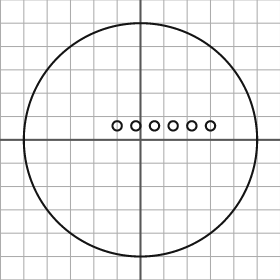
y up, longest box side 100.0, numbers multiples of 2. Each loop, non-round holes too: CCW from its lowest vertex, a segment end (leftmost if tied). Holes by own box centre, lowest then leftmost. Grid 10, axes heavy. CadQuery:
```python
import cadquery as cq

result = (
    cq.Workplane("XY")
    .moveTo(0.0, 0.0)
    .circle(50.0)
    .moveTo(-10.0, 6.0)
    .circle(2.0)
    .moveTo(-2.0, 6.0)
    .circle(2.0)
    .moveTo(6.0, 6.0)
    .circle(2.0)
    .moveTo(14.0, 6.0)
    .circle(2.0)
    .moveTo(22.0, 6.0)
    .circle(2.0)
    .moveTo(30.0, 6.0)
    .circle(2.0)
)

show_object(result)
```